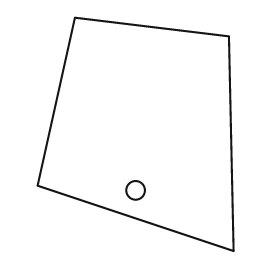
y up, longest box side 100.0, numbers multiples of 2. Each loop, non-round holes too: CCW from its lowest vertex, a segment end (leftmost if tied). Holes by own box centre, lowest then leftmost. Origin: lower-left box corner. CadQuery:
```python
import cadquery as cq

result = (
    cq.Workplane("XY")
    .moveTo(84.0, 0.0)
    .lineTo(82.0, 92.0)
    .lineTo(16.0, 100.0)
    .lineTo(0.0, 28.0)
    .close()
    .moveTo(42.0, 26.0)
    .circle(4.0)
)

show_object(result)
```